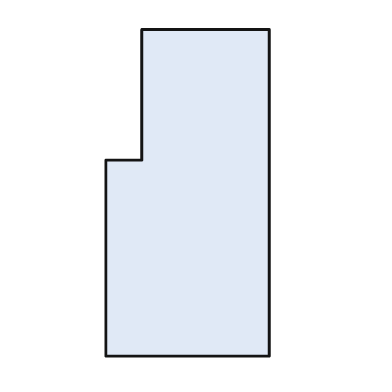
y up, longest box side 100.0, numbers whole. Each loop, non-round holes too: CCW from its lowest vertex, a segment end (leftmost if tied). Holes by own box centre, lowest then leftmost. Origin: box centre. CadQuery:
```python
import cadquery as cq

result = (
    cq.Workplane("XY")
    .moveTo(-25.0, -50.0)
    .lineTo(25.0, -50.0)
    .lineTo(25.0, 50.0)
    .lineTo(-14.0, 50.0)
    .lineTo(-14.0, 10.0)
    .lineTo(-25.0, 10.0)
    .close()
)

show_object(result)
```